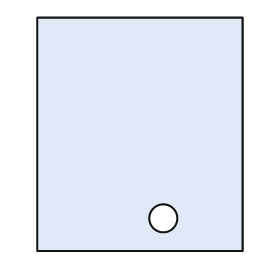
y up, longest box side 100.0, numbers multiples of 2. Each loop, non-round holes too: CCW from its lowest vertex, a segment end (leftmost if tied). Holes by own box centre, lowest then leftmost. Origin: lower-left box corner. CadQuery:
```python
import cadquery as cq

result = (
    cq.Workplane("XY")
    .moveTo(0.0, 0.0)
    .lineTo(88.0, 0.0)
    .lineTo(88.0, 100.0)
    .lineTo(0.0, 100.0)
    .close()
    .moveTo(54.0, 14.0)
    .circle(6.0)
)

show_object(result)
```